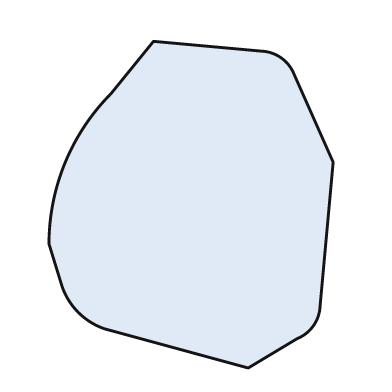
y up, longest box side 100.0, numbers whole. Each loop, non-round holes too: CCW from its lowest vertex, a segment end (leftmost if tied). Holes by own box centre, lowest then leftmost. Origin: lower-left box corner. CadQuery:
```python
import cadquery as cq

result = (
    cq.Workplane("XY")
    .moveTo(61.0, 0.0)
    .lineTo(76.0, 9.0)
    .threePointArc((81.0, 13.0), (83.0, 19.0))
    .lineTo(87.0, 63.0)
    .lineTo(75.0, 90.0)
    .threePointArc((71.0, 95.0), (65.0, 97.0))
    .lineTo(32.0, 100.0)
    .lineTo(19.0, 84.0)
    .threePointArc((5.0, 63.0), (0.0, 38.0))
    .lineTo(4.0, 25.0)
    .threePointArc((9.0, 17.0), (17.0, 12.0))
    .close()
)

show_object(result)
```